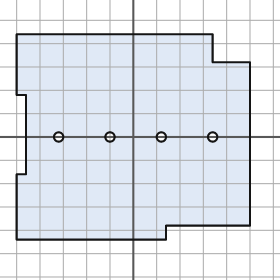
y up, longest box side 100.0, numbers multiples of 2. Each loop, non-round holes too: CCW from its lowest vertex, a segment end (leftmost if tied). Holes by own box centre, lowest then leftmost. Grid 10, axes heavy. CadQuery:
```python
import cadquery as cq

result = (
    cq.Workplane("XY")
    .moveTo(-50.0, -44.0)
    .lineTo(14.0, -44.0)
    .lineTo(14.0, -38.0)
    .lineTo(50.0, -38.0)
    .lineTo(50.0, 32.0)
    .lineTo(34.0, 32.0)
    .lineTo(34.0, 44.0)
    .lineTo(-50.0, 44.0)
    .lineTo(-50.0, 18.0)
    .lineTo(-46.0, 18.0)
    .lineTo(-46.0, -16.0)
    .lineTo(-50.0, -16.0)
    .close()
    .moveTo(-32.0, 0.0)
    .circle(2.0)
    .moveTo(-10.0, 0.0)
    .circle(2.0)
    .moveTo(12.0, 0.0)
    .circle(2.0)
    .moveTo(34.0, 0.0)
    .circle(2.0)
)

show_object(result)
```